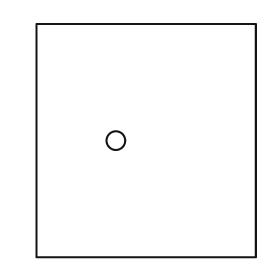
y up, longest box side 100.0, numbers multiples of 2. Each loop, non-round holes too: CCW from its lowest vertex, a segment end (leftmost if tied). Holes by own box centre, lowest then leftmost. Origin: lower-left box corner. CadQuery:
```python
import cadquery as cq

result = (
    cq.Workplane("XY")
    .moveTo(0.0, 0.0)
    .lineTo(94.0, 0.0)
    .lineTo(94.0, 100.0)
    .lineTo(0.0, 100.0)
    .close()
    .moveTo(34.0, 50.0)
    .circle(4.0)
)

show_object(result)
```